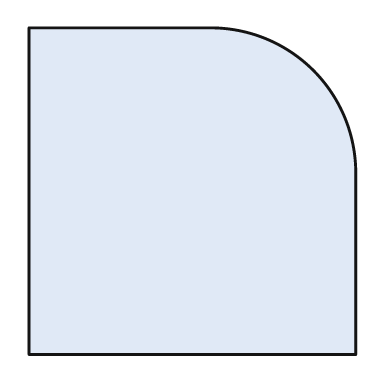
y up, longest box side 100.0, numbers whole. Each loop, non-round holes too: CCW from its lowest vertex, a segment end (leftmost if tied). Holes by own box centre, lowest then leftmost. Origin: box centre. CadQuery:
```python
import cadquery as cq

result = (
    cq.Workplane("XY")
    .moveTo(-50.0, -50.0)
    .lineTo(50.0, -50.0)
    .lineTo(50.0, 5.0)
    .threePointArc((37.0, 37.0), (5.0, 50.0))
    .lineTo(-50.0, 50.0)
    .close()
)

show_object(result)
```